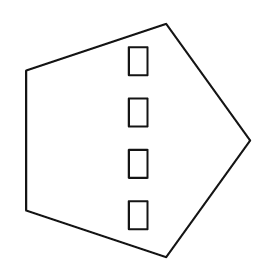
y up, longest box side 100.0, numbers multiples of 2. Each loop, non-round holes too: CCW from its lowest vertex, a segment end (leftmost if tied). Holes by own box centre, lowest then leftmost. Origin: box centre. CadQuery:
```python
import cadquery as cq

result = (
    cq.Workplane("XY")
    .moveTo(12.0, -50.0)
    .lineTo(48.0, 0.0)
    .lineTo(12.0, 50.0)
    .lineTo(-48.0, 30.0)
    .lineTo(-48.0, -30.0)
    .close()
    .moveTo(-4.0, -38.0)
    .lineTo(4.0, -38.0)
    .lineTo(4.0, -26.0)
    .lineTo(-4.0, -26.0)
    .close()
    .moveTo(-4.0, -16.0)
    .lineTo(4.0, -16.0)
    .lineTo(4.0, -4.0)
    .lineTo(-4.0, -4.0)
    .close()
    .moveTo(-4.0, 6.0)
    .lineTo(4.0, 6.0)
    .lineTo(4.0, 18.0)
    .lineTo(-4.0, 18.0)
    .close()
    .moveTo(-4.0, 28.0)
    .lineTo(4.0, 28.0)
    .lineTo(4.0, 40.0)
    .lineTo(-4.0, 40.0)
    .close()
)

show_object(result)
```